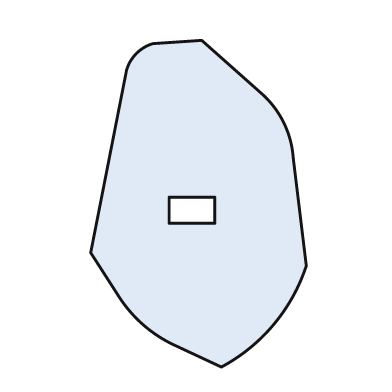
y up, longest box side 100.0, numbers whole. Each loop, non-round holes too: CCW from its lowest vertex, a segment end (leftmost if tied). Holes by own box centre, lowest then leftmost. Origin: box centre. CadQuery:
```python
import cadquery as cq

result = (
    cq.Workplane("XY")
    .moveTo(7.0, -50.0)
    .threePointArc((23.0, -37.0), (33.0, -19.0))
    .lineTo(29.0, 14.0)
    .threePointArc((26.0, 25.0), (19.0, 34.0))
    .lineTo(1.0, 50.0)
    .lineTo(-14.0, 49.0)
    .threePointArc((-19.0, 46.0), (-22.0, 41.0))
    .lineTo(-33.0, -15.0)
    .lineTo(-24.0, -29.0)
    .threePointArc((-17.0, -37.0), (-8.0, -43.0))
    .close()
    .moveTo(-9.0, -6.0)
    .lineTo(5.0, -6.0)
    .lineTo(5.0, 2.0)
    .lineTo(-9.0, 2.0)
    .close()
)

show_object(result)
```